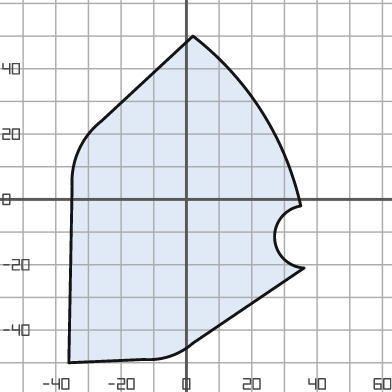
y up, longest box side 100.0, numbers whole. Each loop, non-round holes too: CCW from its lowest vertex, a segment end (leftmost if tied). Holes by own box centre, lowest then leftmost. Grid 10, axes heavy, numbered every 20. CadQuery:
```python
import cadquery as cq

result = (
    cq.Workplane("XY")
    .moveTo(-36.0, -50.0)
    .lineTo(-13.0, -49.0)
    .threePointArc((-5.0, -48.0), (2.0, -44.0))
    .lineTo(36.0, -21.0)
    .threePointArc((27.0, -12.0), (35.0, -2.0))
    .threePointArc((23.0, 27.0), (2.0, 50.0))
    .lineTo(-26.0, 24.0)
    .threePointArc((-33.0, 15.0), (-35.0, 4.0))
    .close()
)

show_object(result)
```